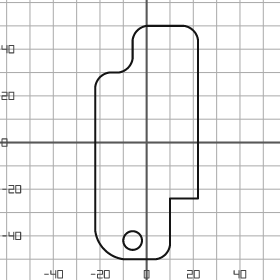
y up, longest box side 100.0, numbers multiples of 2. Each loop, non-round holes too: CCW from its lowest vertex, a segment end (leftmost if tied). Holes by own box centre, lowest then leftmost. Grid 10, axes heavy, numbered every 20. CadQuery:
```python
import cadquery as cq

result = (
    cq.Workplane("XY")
    .moveTo(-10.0, -50.0)
    .lineTo(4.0, -50.0)
    .threePointArc((8.0, -48.0), (10.0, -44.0))
    .lineTo(10.0, -24.0)
    .lineTo(22.0, -24.0)
    .lineTo(22.0, 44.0)
    .threePointArc((20.0, 48.0), (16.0, 50.0))
    .lineTo(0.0, 50.0)
    .threePointArc((-4.0, 48.0), (-6.0, 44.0))
    .lineTo(-6.0, 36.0)
    .threePointArc((-8.0, 32.0), (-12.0, 30.0))
    .lineTo(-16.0, 30.0)
    .threePointArc((-20.0, 28.0), (-22.0, 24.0))
    .lineTo(-22.0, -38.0)
    .threePointArc((-18.0, -46.0), (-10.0, -50.0))
    .close()
    .moveTo(-6.0, -42.0)
    .circle(4.0)
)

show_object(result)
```